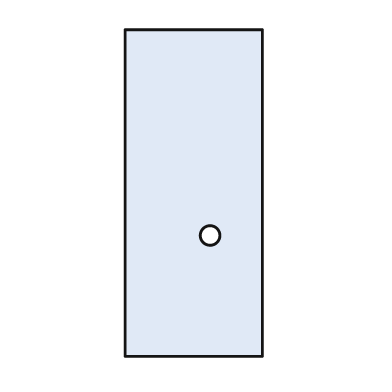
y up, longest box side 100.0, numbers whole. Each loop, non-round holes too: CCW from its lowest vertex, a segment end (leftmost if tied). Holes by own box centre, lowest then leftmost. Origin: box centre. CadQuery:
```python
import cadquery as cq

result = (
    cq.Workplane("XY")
    .moveTo(-21.0, -50.0)
    .lineTo(21.0, -50.0)
    .lineTo(21.0, 50.0)
    .lineTo(-21.0, 50.0)
    .close()
    .moveTo(5.0, -13.0)
    .circle(3.0)
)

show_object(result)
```